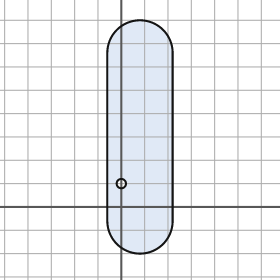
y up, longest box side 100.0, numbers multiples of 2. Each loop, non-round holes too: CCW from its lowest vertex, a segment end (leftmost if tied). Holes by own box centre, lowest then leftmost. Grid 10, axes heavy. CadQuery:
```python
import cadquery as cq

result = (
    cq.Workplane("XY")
    .moveTo(-6.0, -6.0)
    .threePointArc((8.0, -20.0), (22.0, -6.0))
    .lineTo(22.0, 66.0)
    .threePointArc((8.0, 80.0), (-6.0, 66.0))
    .close()
    .moveTo(0.0, 10.0)
    .circle(2.0)
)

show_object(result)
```